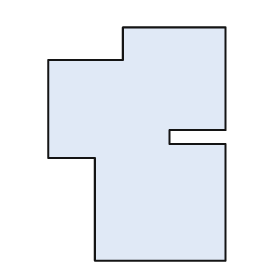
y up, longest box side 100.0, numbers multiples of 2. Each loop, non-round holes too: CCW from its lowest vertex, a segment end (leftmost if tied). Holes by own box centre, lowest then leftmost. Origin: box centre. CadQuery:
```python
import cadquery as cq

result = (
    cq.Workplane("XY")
    .moveTo(-18.0, -50.0)
    .lineTo(38.0, -50.0)
    .lineTo(38.0, 0.0)
    .lineTo(14.0, 0.0)
    .lineTo(14.0, 6.0)
    .lineTo(38.0, 6.0)
    .lineTo(38.0, 50.0)
    .lineTo(-6.0, 50.0)
    .lineTo(-6.0, 36.0)
    .lineTo(-38.0, 36.0)
    .lineTo(-38.0, -6.0)
    .lineTo(-18.0, -6.0)
    .close()
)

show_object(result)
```